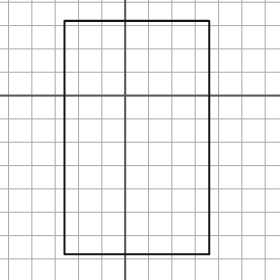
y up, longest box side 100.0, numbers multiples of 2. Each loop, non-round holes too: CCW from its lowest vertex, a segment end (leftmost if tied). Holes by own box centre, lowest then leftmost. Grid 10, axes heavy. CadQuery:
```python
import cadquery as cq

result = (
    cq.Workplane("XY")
    .moveTo(-26.0, -68.0)
    .lineTo(36.0, -68.0)
    .lineTo(36.0, 32.0)
    .lineTo(-26.0, 32.0)
    .close()
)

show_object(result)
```